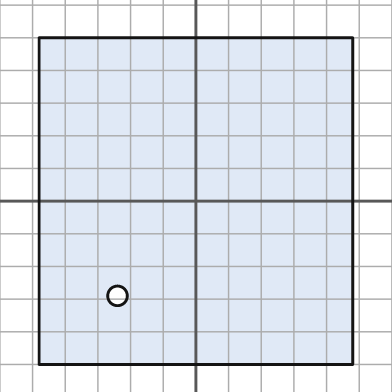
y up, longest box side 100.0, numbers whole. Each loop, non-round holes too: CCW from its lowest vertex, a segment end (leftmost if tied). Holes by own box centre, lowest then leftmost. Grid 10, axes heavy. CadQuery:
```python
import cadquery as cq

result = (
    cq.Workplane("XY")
    .moveTo(-48.0, -50.0)
    .lineTo(48.0, -50.0)
    .lineTo(48.0, 50.0)
    .lineTo(-48.0, 50.0)
    .close()
    .moveTo(-24.0, -29.0)
    .circle(3.0)
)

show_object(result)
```